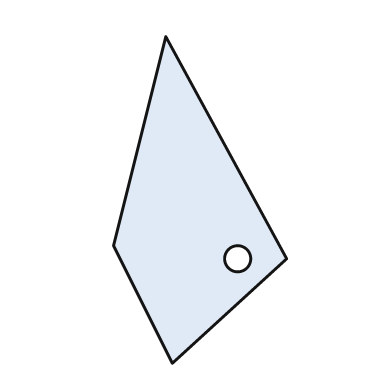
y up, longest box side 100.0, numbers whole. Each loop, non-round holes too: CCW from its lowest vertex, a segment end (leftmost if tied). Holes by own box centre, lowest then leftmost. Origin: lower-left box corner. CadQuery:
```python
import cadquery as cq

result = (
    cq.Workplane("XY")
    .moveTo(18.0, 0.0)
    .lineTo(53.0, 32.0)
    .lineTo(16.0, 100.0)
    .lineTo(0.0, 36.0)
    .close()
    .moveTo(38.0, 32.0)
    .circle(4.0)
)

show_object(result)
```